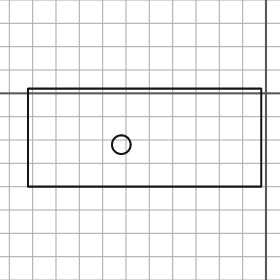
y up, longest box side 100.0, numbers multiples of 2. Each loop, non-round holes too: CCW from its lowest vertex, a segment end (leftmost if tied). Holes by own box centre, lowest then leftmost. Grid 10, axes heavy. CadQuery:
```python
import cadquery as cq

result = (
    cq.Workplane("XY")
    .moveTo(-102.0, -40.0)
    .lineTo(-2.0, -40.0)
    .lineTo(-2.0, 2.0)
    .lineTo(-102.0, 2.0)
    .close()
    .moveTo(-62.0, -22.0)
    .circle(4.0)
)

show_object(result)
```